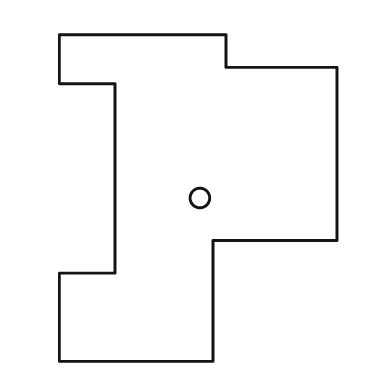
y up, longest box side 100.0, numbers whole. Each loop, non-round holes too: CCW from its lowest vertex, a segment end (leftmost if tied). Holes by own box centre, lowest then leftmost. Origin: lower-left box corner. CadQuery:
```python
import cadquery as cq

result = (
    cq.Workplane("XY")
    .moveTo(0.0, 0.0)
    .lineTo(47.0, 0.0)
    .lineTo(47.0, 37.0)
    .lineTo(85.0, 37.0)
    .lineTo(85.0, 90.0)
    .lineTo(51.0, 90.0)
    .lineTo(51.0, 100.0)
    .lineTo(0.0, 100.0)
    .lineTo(0.0, 85.0)
    .lineTo(17.0, 85.0)
    .lineTo(17.0, 27.0)
    .lineTo(0.0, 27.0)
    .close()
    .moveTo(43.0, 50.0)
    .circle(3.0)
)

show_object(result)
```